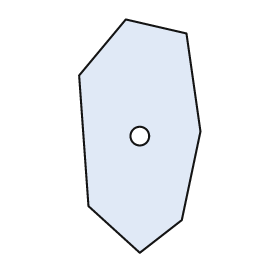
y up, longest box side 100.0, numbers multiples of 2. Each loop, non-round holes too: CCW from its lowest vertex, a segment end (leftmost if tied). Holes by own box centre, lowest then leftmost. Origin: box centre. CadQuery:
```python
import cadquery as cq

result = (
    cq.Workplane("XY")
    .moveTo(0.0, -50.0)
    .lineTo(18.0, -36.0)
    .lineTo(26.0, 2.0)
    .lineTo(20.0, 44.0)
    .lineTo(-6.0, 50.0)
    .lineTo(-26.0, 26.0)
    .lineTo(-22.0, -30.0)
    .close()
    .moveTo(0.0, 0.0)
    .circle(4.0)
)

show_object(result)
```